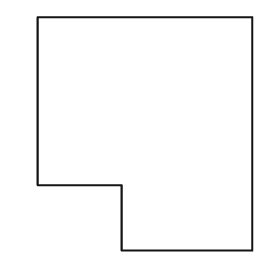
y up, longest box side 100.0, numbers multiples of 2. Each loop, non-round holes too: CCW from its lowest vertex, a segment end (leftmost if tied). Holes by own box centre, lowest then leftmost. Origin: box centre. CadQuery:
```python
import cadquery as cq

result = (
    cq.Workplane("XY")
    .moveTo(-10.0, -50.0)
    .lineTo(46.0, -50.0)
    .lineTo(46.0, 50.0)
    .lineTo(-46.0, 50.0)
    .lineTo(-46.0, -22.0)
    .lineTo(-10.0, -22.0)
    .close()
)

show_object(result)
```